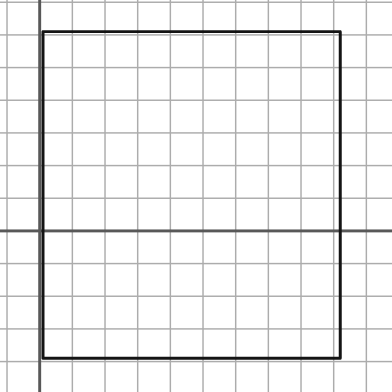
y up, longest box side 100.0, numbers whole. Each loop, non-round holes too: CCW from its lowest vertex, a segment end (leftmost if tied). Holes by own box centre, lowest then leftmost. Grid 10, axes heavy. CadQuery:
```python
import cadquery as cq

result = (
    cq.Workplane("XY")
    .moveTo(1.0, -39.0)
    .lineTo(92.0, -39.0)
    .lineTo(92.0, 61.0)
    .lineTo(1.0, 61.0)
    .close()
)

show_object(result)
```